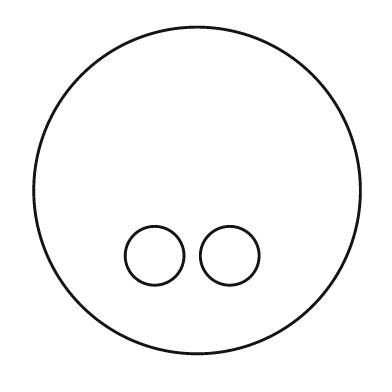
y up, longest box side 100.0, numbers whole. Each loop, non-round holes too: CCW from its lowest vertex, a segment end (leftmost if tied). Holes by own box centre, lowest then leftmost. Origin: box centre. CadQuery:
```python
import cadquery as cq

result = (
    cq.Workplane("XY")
    .moveTo(0.0, 0.0)
    .circle(50.0)
    .moveTo(-13.0, -20.0)
    .circle(9.0)
    .moveTo(10.0, -20.0)
    .circle(9.0)
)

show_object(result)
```